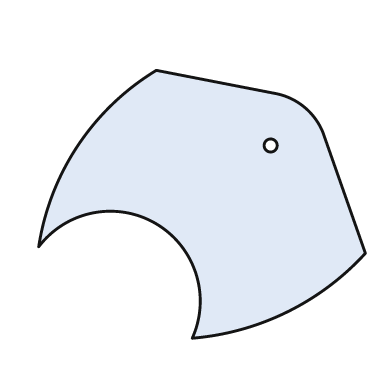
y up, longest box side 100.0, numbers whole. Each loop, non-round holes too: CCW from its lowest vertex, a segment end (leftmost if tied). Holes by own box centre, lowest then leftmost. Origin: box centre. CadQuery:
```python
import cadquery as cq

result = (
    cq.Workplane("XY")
    .moveTo(-3.0, -41.0)
    .threePointArc((26.0, -33.0), (50.0, -15.0))
    .lineTo(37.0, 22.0)
    .threePointArc((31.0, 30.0), (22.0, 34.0))
    .lineTo(-14.0, 41.0)
    .threePointArc((-38.0, 18.0), (-50.0, -13.0))
    .threePointArc((-14.0, -6.0), (-3.0, -41.0))
    .close()
    .moveTo(21.0, 18.0)
    .circle(2.0)
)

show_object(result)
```